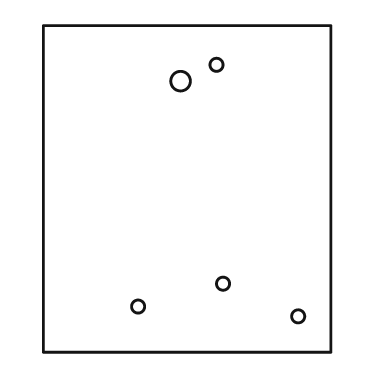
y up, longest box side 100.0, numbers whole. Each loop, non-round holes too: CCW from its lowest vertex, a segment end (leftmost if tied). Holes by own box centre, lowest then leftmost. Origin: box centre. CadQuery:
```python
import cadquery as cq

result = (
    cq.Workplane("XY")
    .moveTo(-44.0, -50.0)
    .lineTo(44.0, -50.0)
    .lineTo(44.0, 50.0)
    .lineTo(-44.0, 50.0)
    .close()
    .moveTo(34.0, -39.0)
    .circle(2.0)
    .moveTo(-15.0, -36.0)
    .circle(2.0)
    .moveTo(11.0, -29.0)
    .circle(2.0)
    .moveTo(-2.0, 33.0)
    .circle(3.0)
    .moveTo(9.0, 38.0)
    .circle(2.0)
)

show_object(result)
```